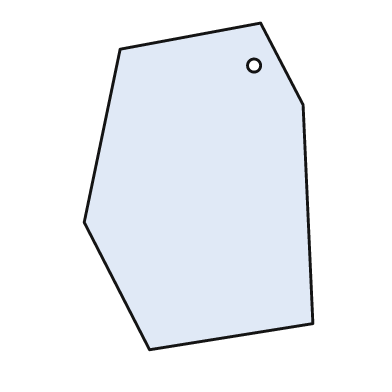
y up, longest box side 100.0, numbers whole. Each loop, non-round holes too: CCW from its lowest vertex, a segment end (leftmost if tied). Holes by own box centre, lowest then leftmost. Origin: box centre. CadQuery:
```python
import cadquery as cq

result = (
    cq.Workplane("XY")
    .moveTo(-15.0, -50.0)
    .lineTo(35.0, -42.0)
    .lineTo(32.0, 25.0)
    .lineTo(19.0, 50.0)
    .lineTo(-24.0, 42.0)
    .lineTo(-35.0, -11.0)
    .close()
    .moveTo(17.0, 37.0)
    .circle(2.0)
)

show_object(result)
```